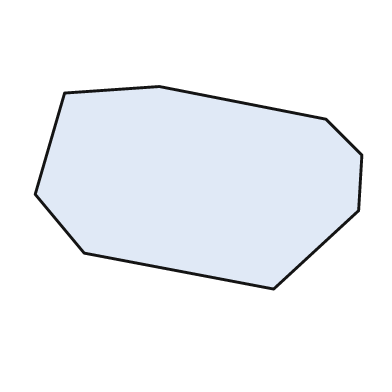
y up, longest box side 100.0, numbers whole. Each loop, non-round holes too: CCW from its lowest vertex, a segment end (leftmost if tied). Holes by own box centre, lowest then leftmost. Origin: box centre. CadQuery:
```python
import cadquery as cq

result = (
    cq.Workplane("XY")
    .moveTo(23.0, -31.0)
    .lineTo(49.0, -7.0)
    .lineTo(50.0, 10.0)
    .lineTo(39.0, 21.0)
    .lineTo(-12.0, 31.0)
    .lineTo(-41.0, 29.0)
    .lineTo(-50.0, -2.0)
    .lineTo(-35.0, -20.0)
    .close()
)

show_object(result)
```